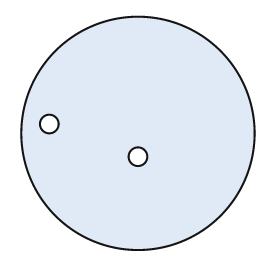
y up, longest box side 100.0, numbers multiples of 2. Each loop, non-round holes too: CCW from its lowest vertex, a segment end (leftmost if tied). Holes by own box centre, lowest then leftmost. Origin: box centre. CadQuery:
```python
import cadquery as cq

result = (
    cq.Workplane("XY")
    .moveTo(0.0, 0.0)
    .circle(50.0)
    .moveTo(0.0, -10.0)
    .circle(4.0)
    .moveTo(-38.0, 4.0)
    .circle(4.0)
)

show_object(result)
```